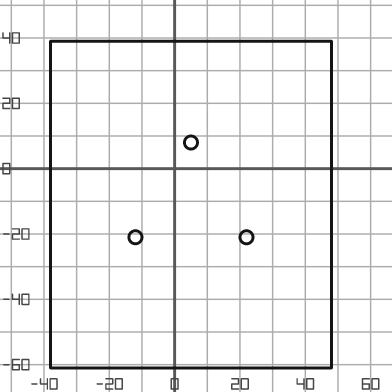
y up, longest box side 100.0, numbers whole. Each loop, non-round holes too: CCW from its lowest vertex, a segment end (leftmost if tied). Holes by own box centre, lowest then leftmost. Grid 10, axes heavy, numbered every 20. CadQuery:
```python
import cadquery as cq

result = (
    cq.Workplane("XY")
    .moveTo(-38.0, -61.0)
    .lineTo(48.0, -61.0)
    .lineTo(48.0, 39.0)
    .lineTo(-38.0, 39.0)
    .close()
    .moveTo(-12.0, -21.0)
    .circle(2.0)
    .moveTo(22.0, -21.0)
    .circle(2.0)
    .moveTo(5.0, 8.0)
    .circle(2.0)
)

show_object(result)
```